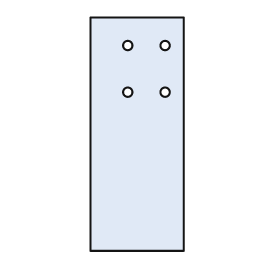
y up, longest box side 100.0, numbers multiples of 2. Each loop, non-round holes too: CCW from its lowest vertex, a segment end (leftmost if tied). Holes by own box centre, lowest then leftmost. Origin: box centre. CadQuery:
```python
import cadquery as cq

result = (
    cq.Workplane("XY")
    .moveTo(-20.0, -50.0)
    .lineTo(20.0, -50.0)
    .lineTo(20.0, 50.0)
    .lineTo(-20.0, 50.0)
    .close()
    .moveTo(-4.0, 18.0)
    .circle(2.0)
    .moveTo(12.0, 18.0)
    .circle(2.0)
    .moveTo(-4.0, 38.0)
    .circle(2.0)
    .moveTo(12.0, 38.0)
    .circle(2.0)
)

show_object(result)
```